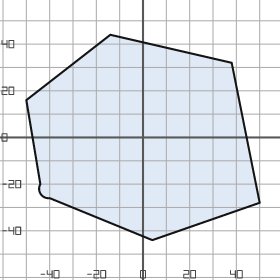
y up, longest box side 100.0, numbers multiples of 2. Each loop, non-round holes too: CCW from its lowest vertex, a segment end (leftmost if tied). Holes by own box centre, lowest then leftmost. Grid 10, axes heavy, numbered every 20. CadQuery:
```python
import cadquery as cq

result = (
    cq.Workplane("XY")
    .moveTo(4.0, -44.0)
    .lineTo(50.0, -28.0)
    .lineTo(38.0, 32.0)
    .lineTo(-14.0, 44.0)
    .lineTo(-50.0, 16.0)
    .lineTo(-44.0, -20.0)
    .threePointArc((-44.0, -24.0), (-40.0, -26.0))
    .close()
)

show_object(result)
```